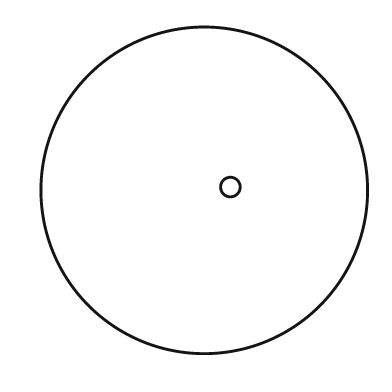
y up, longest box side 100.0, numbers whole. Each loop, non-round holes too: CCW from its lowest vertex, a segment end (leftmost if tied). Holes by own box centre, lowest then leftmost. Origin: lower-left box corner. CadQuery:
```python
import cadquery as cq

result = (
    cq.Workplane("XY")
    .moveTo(50.0, 50.0)
    .circle(50.0)
    .moveTo(58.0, 51.0)
    .circle(3.0)
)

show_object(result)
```